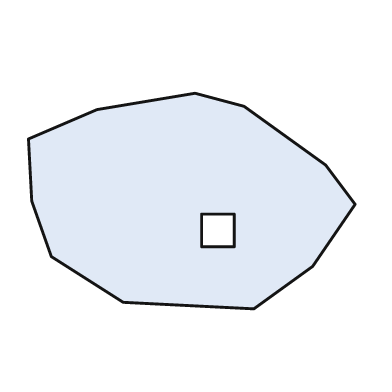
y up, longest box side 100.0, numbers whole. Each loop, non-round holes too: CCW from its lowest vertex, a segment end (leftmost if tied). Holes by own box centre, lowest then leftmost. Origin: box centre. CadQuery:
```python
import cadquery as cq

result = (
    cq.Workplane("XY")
    .moveTo(19.0, -33.0)
    .lineTo(37.0, -20.0)
    .lineTo(50.0, -1.0)
    .lineTo(41.0, 11.0)
    .lineTo(16.0, 29.0)
    .lineTo(1.0, 33.0)
    .lineTo(-29.0, 28.0)
    .lineTo(-50.0, 19.0)
    .lineTo(-49.0, 0.0)
    .lineTo(-43.0, -17.0)
    .lineTo(-21.0, -31.0)
    .close()
    .moveTo(3.0, -14.0)
    .lineTo(13.0, -14.0)
    .lineTo(13.0, -4.0)
    .lineTo(3.0, -4.0)
    .close()
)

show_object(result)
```